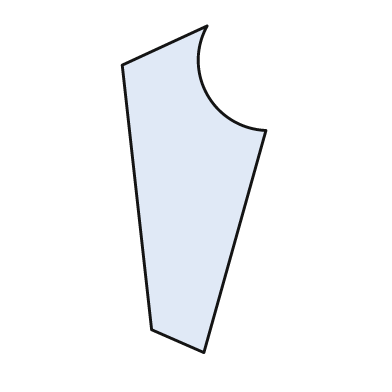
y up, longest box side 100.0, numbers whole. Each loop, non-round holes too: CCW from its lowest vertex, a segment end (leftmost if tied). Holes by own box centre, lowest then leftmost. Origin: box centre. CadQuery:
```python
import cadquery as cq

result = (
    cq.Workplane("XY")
    .moveTo(3.0, -50.0)
    .lineTo(22.0, 18.0)
    .threePointArc((4.0, 29.0), (4.0, 50.0))
    .lineTo(-22.0, 38.0)
    .lineTo(-13.0, -43.0)
    .close()
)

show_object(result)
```